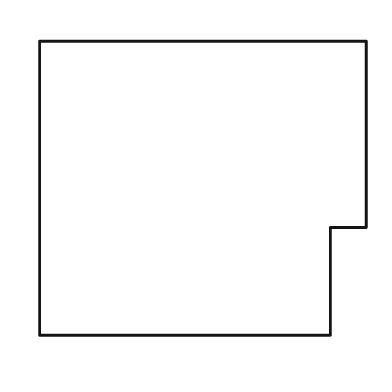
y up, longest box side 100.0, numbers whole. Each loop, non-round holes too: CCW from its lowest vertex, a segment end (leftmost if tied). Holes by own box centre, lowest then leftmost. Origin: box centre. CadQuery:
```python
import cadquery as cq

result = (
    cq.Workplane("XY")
    .moveTo(-50.0, -45.0)
    .lineTo(39.0, -45.0)
    .lineTo(39.0, -12.0)
    .lineTo(50.0, -12.0)
    .lineTo(50.0, 45.0)
    .lineTo(-50.0, 45.0)
    .close()
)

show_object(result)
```